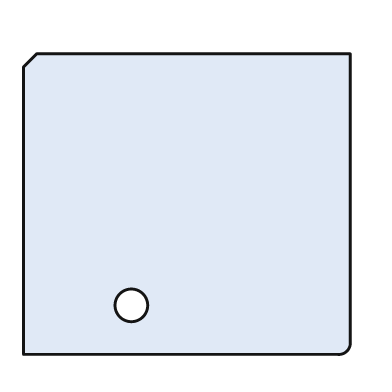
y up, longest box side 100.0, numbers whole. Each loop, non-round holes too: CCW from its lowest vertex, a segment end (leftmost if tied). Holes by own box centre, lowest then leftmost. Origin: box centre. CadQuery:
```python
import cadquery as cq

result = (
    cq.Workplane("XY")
    .moveTo(-50.0, -46.0)
    .lineTo(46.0, -46.0)
    .threePointArc((49.0, -45.0), (50.0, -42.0))
    .lineTo(50.0, 46.0)
    .lineTo(-46.0, 46.0)
    .lineTo(-50.0, 42.0)
    .close()
    .moveTo(-17.0, -31.0)
    .circle(5.0)
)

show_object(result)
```